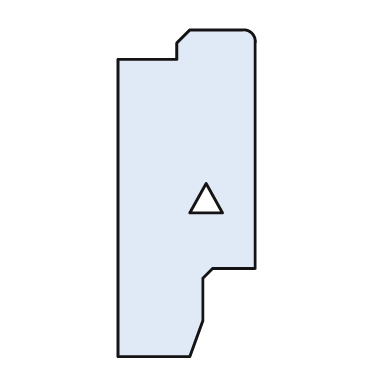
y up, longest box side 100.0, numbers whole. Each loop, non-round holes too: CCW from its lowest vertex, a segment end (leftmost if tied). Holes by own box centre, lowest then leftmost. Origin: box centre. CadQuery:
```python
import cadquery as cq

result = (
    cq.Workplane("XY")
    .moveTo(-21.0, -50.0)
    .lineTo(1.0, -50.0)
    .lineTo(5.0, -39.0)
    .lineTo(5.0, -26.0)
    .lineTo(8.0, -23.0)
    .lineTo(21.0, -23.0)
    .lineTo(21.0, 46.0)
    .threePointArc((20.0, 49.0), (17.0, 50.0))
    .lineTo(1.0, 50.0)
    .lineTo(-3.0, 46.0)
    .lineTo(-3.0, 41.0)
    .lineTo(-21.0, 41.0)
    .close()
    .moveTo(1.0, -6.0)
    .lineTo(11.0, -6.0)
    .lineTo(6.0, 3.0)
    .close()
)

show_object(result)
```